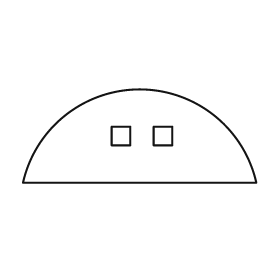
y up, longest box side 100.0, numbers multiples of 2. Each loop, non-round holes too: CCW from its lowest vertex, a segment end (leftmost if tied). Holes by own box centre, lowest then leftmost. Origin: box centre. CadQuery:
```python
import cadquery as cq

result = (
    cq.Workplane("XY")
    .moveTo(-50.0, -20.0)
    .lineTo(50.0, -20.0)
    .threePointArc((0.0, 20.0), (-50.0, -20.0))
    .close()
    .moveTo(-12.0, -4.0)
    .lineTo(-4.0, -4.0)
    .lineTo(-4.0, 4.0)
    .lineTo(-12.0, 4.0)
    .close()
    .moveTo(6.0, -4.0)
    .lineTo(14.0, -4.0)
    .lineTo(14.0, 4.0)
    .lineTo(6.0, 4.0)
    .close()
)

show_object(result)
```